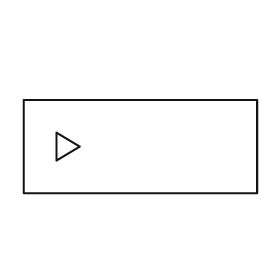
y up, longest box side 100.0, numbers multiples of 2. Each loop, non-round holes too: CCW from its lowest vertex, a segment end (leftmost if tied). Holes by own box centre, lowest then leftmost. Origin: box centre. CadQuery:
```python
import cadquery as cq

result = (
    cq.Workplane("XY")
    .moveTo(-50.0, -20.0)
    .lineTo(50.0, -20.0)
    .lineTo(50.0, 20.0)
    .lineTo(-50.0, 20.0)
    .close()
    .moveTo(-36.0, -6.0)
    .lineTo(-26.0, 0.0)
    .lineTo(-36.0, 6.0)
    .close()
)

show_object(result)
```